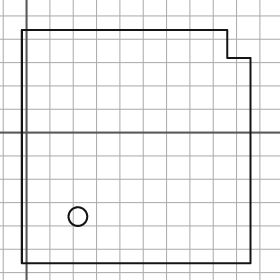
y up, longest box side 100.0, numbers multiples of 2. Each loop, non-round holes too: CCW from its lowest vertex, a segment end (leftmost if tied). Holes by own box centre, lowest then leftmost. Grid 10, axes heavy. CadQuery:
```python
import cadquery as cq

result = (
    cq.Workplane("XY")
    .moveTo(-2.0, -56.0)
    .lineTo(96.0, -56.0)
    .lineTo(96.0, 32.0)
    .lineTo(86.0, 32.0)
    .lineTo(86.0, 44.0)
    .lineTo(-2.0, 44.0)
    .close()
    .moveTo(22.0, -36.0)
    .circle(4.0)
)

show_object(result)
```